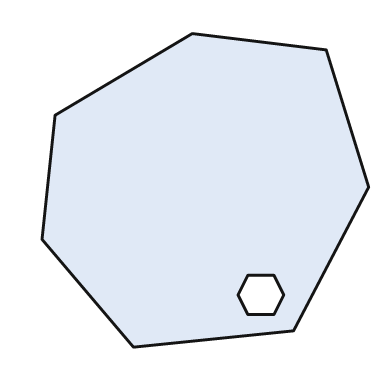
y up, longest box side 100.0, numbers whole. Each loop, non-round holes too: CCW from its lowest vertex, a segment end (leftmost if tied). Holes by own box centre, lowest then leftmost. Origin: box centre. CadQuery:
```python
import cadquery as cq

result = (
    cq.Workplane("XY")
    .moveTo(-22.0, -48.0)
    .lineTo(27.0, -43.0)
    .lineTo(50.0, 1.0)
    .lineTo(37.0, 43.0)
    .lineTo(-4.0, 48.0)
    .lineTo(-46.0, 23.0)
    .lineTo(-50.0, -15.0)
    .close()
    .moveTo(13.0, -38.0)
    .lineTo(21.0, -38.0)
    .lineTo(24.0, -32.0)
    .lineTo(21.0, -26.0)
    .lineTo(13.0, -26.0)
    .lineTo(10.0, -32.0)
    .close()
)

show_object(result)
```